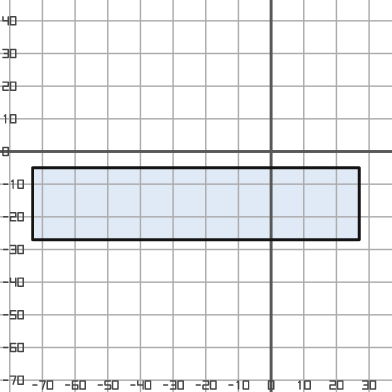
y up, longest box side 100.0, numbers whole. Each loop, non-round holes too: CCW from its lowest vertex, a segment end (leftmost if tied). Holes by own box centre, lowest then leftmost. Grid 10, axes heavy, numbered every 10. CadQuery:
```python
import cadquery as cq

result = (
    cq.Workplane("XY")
    .moveTo(-73.0, -27.0)
    .lineTo(27.0, -27.0)
    .lineTo(27.0, -5.0)
    .lineTo(-73.0, -5.0)
    .close()
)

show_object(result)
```